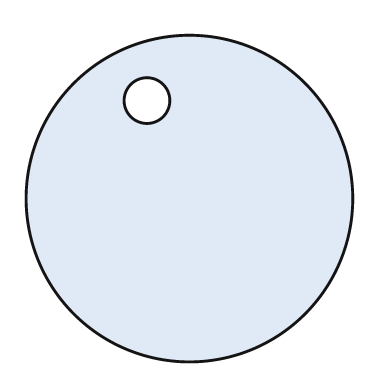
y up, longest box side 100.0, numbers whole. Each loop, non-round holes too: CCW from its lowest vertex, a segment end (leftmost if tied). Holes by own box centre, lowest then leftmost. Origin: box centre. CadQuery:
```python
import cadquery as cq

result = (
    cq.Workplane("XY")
    .moveTo(0.0, 0.0)
    .circle(50.0)
    .moveTo(-13.0, 30.0)
    .circle(7.0)
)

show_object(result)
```